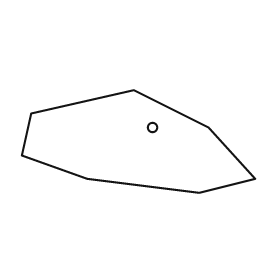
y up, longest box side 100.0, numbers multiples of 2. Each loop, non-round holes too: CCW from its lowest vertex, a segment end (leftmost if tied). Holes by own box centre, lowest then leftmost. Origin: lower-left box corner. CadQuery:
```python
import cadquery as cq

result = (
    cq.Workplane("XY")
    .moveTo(76.0, 0.0)
    .lineTo(100.0, 6.0)
    .lineTo(80.0, 28.0)
    .lineTo(48.0, 44.0)
    .lineTo(4.0, 34.0)
    .lineTo(0.0, 16.0)
    .lineTo(28.0, 6.0)
    .close()
    .moveTo(56.0, 28.0)
    .circle(2.0)
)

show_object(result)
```